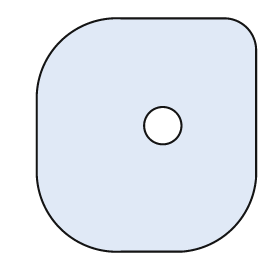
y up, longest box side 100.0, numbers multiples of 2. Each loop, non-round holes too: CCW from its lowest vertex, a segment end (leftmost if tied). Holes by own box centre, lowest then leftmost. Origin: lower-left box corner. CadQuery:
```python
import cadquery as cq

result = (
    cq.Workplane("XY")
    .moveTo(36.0, 0.0)
    .lineTo(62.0, 0.0)
    .threePointArc((84.0, 10.0), (94.0, 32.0))
    .lineTo(94.0, 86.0)
    .threePointArc((90.0, 96.0), (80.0, 100.0))
    .lineTo(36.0, 100.0)
    .threePointArc((10.0, 90.0), (0.0, 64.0))
    .lineTo(0.0, 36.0)
    .threePointArc((10.0, 10.0), (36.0, 0.0))
    .close()
    .moveTo(54.0, 54.0)
    .circle(8.0)
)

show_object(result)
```